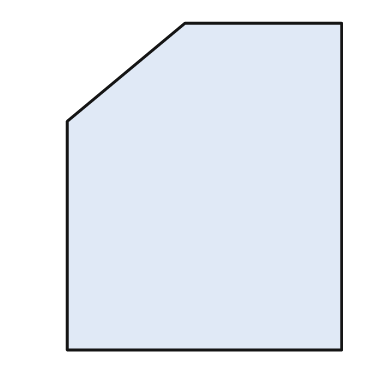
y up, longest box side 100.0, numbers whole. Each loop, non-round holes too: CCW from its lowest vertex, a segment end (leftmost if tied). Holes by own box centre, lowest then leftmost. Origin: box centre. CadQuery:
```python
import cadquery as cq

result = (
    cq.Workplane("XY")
    .moveTo(-42.0, -50.0)
    .lineTo(42.0, -50.0)
    .lineTo(42.0, 50.0)
    .lineTo(-6.0, 50.0)
    .lineTo(-42.0, 20.0)
    .close()
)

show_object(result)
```